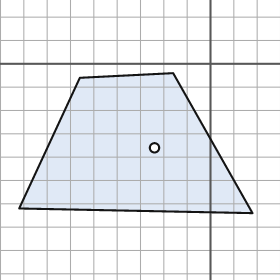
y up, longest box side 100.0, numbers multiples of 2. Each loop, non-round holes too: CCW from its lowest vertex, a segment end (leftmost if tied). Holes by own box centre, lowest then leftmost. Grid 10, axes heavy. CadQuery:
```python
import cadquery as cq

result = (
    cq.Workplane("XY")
    .moveTo(18.0, -64.0)
    .lineTo(-16.0, -4.0)
    .lineTo(-56.0, -6.0)
    .lineTo(-82.0, -62.0)
    .close()
    .moveTo(-24.0, -36.0)
    .circle(2.0)
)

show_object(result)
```